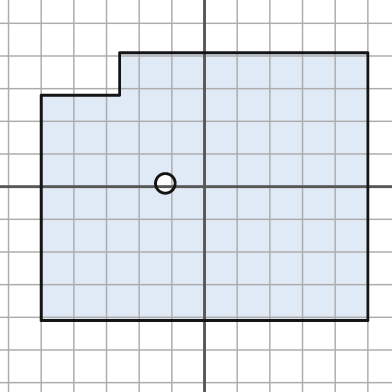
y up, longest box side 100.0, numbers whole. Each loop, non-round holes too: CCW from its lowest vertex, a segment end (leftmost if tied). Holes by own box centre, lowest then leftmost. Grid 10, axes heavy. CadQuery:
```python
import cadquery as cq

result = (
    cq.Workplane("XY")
    .moveTo(-50.0, -41.0)
    .lineTo(50.0, -41.0)
    .lineTo(50.0, 41.0)
    .lineTo(-26.0, 41.0)
    .lineTo(-26.0, 28.0)
    .lineTo(-50.0, 28.0)
    .close()
    .moveTo(-12.0, 1.0)
    .circle(3.0)
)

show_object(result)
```